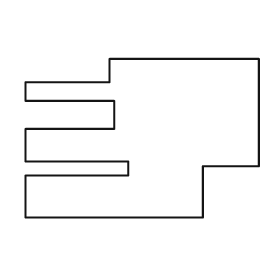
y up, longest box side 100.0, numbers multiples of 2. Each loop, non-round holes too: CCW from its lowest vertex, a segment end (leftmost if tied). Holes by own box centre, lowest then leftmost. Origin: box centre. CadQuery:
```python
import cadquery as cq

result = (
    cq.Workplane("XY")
    .moveTo(-50.0, -34.0)
    .lineTo(26.0, -34.0)
    .lineTo(26.0, -12.0)
    .lineTo(50.0, -12.0)
    .lineTo(50.0, 34.0)
    .lineTo(-14.0, 34.0)
    .lineTo(-14.0, 24.0)
    .lineTo(-50.0, 24.0)
    .lineTo(-50.0, 16.0)
    .lineTo(-12.0, 16.0)
    .lineTo(-12.0, 4.0)
    .lineTo(-50.0, 4.0)
    .lineTo(-50.0, -10.0)
    .lineTo(-6.0, -10.0)
    .lineTo(-6.0, -16.0)
    .lineTo(-50.0, -16.0)
    .close()
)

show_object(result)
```